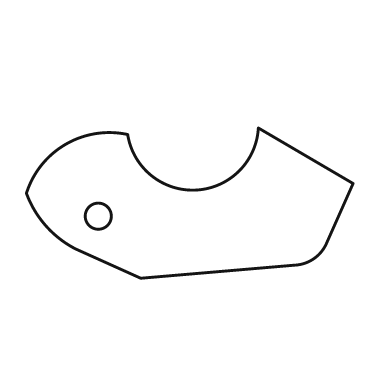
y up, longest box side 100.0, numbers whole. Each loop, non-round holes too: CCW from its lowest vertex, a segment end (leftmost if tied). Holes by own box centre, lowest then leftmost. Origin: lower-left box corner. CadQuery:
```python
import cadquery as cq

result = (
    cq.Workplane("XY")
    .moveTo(35.0, 0.0)
    .lineTo(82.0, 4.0)
    .threePointArc((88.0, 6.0), (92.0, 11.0))
    .lineTo(100.0, 29.0)
    .lineTo(71.0, 46.0)
    .threePointArc((52.0, 27.0), (31.0, 44.0))
    .threePointArc((12.0, 41.0), (0.0, 26.0))
    .threePointArc((6.0, 16.0), (15.0, 9.0))
    .close()
    .moveTo(22.0, 19.0)
    .circle(4.0)
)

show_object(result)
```